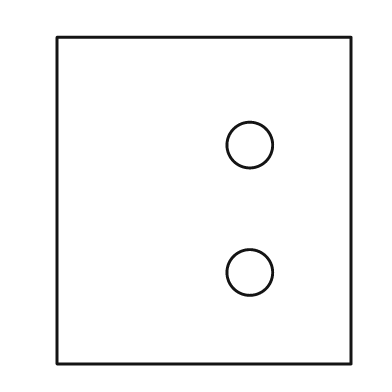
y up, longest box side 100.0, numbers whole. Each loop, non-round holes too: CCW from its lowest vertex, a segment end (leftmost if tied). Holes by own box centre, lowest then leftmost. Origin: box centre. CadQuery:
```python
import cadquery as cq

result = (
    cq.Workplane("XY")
    .moveTo(-45.0, -50.0)
    .lineTo(45.0, -50.0)
    .lineTo(45.0, 50.0)
    .lineTo(-45.0, 50.0)
    .close()
    .moveTo(14.0, -22.0)
    .circle(7.0)
    .moveTo(14.0, 17.0)
    .circle(7.0)
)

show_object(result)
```